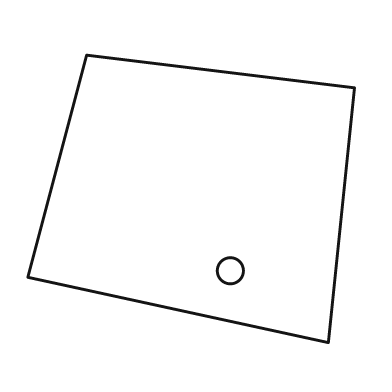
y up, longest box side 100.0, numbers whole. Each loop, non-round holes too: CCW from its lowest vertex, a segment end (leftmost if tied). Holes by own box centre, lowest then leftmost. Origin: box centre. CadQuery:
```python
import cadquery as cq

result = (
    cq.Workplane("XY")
    .moveTo(42.0, -44.0)
    .lineTo(50.0, 34.0)
    .lineTo(-32.0, 44.0)
    .lineTo(-50.0, -24.0)
    .close()
    .moveTo(12.0, -22.0)
    .circle(4.0)
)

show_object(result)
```